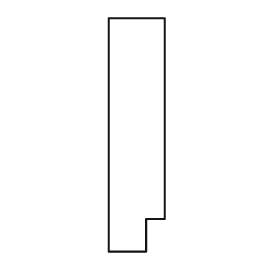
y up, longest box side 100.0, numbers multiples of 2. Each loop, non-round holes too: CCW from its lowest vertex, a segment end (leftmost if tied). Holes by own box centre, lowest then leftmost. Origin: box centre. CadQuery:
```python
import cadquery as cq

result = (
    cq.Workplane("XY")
    .moveTo(-12.0, -50.0)
    .lineTo(4.0, -50.0)
    .lineTo(4.0, -36.0)
    .lineTo(12.0, -36.0)
    .lineTo(12.0, 50.0)
    .lineTo(-12.0, 50.0)
    .close()
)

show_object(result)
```